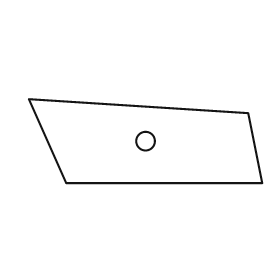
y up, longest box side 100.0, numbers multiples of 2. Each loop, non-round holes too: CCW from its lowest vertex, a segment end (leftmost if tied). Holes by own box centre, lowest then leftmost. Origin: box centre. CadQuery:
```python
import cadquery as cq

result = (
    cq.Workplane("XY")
    .moveTo(-34.0, -18.0)
    .lineTo(50.0, -18.0)
    .lineTo(44.0, 12.0)
    .lineTo(-50.0, 18.0)
    .close()
    .moveTo(0.0, 0.0)
    .circle(4.0)
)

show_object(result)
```